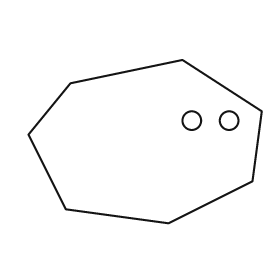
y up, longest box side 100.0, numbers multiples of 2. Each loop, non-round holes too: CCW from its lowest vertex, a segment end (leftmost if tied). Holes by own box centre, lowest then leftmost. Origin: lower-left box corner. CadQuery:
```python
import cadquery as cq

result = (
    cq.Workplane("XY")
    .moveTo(60.0, 0.0)
    .lineTo(96.0, 18.0)
    .lineTo(100.0, 48.0)
    .lineTo(66.0, 70.0)
    .lineTo(18.0, 60.0)
    .lineTo(0.0, 38.0)
    .lineTo(16.0, 6.0)
    .close()
    .moveTo(70.0, 44.0)
    .circle(4.0)
    .moveTo(86.0, 44.0)
    .circle(4.0)
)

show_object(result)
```